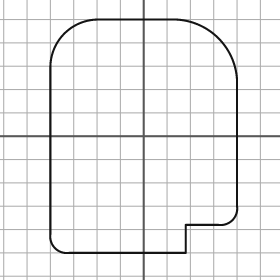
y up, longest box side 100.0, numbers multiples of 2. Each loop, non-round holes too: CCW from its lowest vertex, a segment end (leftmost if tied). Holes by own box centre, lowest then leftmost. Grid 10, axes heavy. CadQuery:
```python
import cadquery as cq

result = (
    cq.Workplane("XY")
    .moveTo(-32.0, -50.0)
    .lineTo(18.0, -50.0)
    .lineTo(18.0, -38.0)
    .lineTo(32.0, -38.0)
    .threePointArc((38.0, -36.0), (40.0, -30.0))
    .lineTo(40.0, 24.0)
    .threePointArc((32.0, 42.0), (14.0, 50.0))
    .lineTo(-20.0, 50.0)
    .threePointArc((-34.0, 44.0), (-40.0, 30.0))
    .lineTo(-40.0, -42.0)
    .threePointArc((-38.0, -48.0), (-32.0, -50.0))
    .close()
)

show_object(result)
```